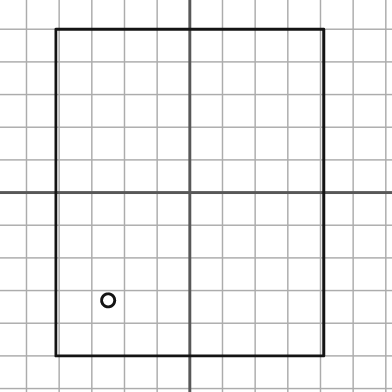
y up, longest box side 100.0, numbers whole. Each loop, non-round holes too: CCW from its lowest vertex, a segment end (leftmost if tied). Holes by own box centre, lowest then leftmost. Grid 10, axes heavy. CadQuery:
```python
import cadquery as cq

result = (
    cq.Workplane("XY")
    .moveTo(-41.0, -50.0)
    .lineTo(41.0, -50.0)
    .lineTo(41.0, 50.0)
    .lineTo(-41.0, 50.0)
    .close()
    .moveTo(-25.0, -33.0)
    .circle(2.0)
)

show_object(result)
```